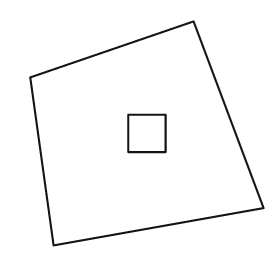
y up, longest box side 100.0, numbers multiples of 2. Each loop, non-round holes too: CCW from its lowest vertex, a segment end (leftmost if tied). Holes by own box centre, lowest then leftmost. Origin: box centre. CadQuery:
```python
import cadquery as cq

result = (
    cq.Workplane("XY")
    .moveTo(-40.0, -48.0)
    .lineTo(50.0, -32.0)
    .lineTo(20.0, 48.0)
    .lineTo(-50.0, 24.0)
    .close()
    .moveTo(-8.0, -8.0)
    .lineTo(8.0, -8.0)
    .lineTo(8.0, 8.0)
    .lineTo(-8.0, 8.0)
    .close()
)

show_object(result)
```